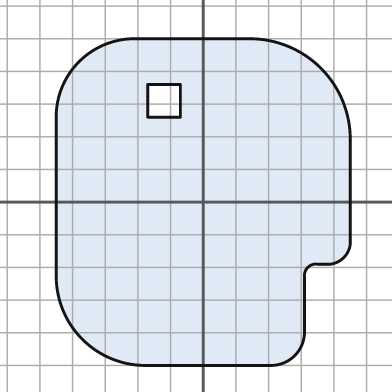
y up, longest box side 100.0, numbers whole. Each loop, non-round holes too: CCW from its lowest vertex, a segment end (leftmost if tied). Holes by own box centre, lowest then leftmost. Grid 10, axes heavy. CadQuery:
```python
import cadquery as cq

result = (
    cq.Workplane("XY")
    .moveTo(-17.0, -50.0)
    .lineTo(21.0, -50.0)
    .threePointArc((28.0, -47.0), (31.0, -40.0))
    .lineTo(31.0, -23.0)
    .threePointArc((32.0, -20.0), (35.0, -19.0))
    .lineTo(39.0, -19.0)
    .threePointArc((43.0, -17.0), (45.0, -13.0))
    .lineTo(45.0, 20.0)
    .threePointArc((36.0, 41.0), (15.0, 50.0))
    .lineTo(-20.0, 50.0)
    .threePointArc((-38.0, 43.0), (-45.0, 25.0))
    .lineTo(-45.0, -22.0)
    .threePointArc((-37.0, -42.0), (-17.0, -50.0))
    .close()
    .moveTo(-17.0, 26.0)
    .lineTo(-7.0, 26.0)
    .lineTo(-7.0, 36.0)
    .lineTo(-17.0, 36.0)
    .close()
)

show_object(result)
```